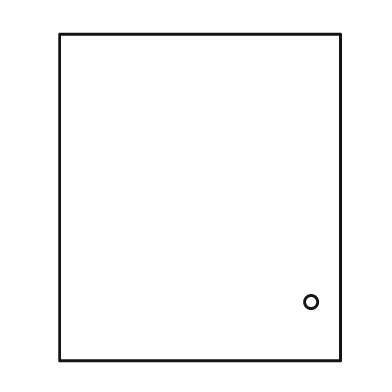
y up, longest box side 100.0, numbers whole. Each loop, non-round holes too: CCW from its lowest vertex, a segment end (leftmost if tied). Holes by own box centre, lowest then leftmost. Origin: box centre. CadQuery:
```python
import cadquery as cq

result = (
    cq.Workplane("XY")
    .moveTo(-43.0, -50.0)
    .lineTo(43.0, -50.0)
    .lineTo(43.0, 50.0)
    .lineTo(-43.0, 50.0)
    .close()
    .moveTo(34.0, -32.0)
    .circle(2.0)
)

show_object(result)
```